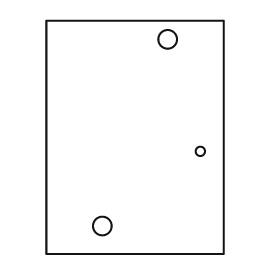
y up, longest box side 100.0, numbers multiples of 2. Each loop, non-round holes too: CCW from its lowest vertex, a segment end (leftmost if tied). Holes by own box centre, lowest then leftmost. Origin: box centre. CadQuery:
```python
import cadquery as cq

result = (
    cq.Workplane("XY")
    .moveTo(-38.0, -50.0)
    .lineTo(38.0, -50.0)
    .lineTo(38.0, 50.0)
    .lineTo(-38.0, 50.0)
    .close()
    .moveTo(-14.0, -38.0)
    .circle(4.0)
    .moveTo(28.0, -6.0)
    .circle(2.0)
    .moveTo(14.0, 42.0)
    .circle(4.0)
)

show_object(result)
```